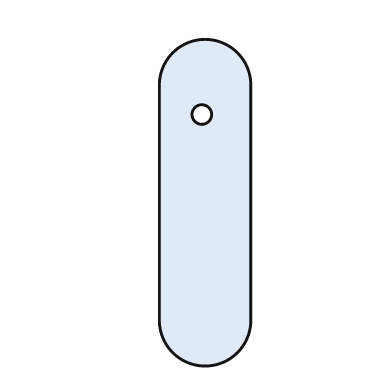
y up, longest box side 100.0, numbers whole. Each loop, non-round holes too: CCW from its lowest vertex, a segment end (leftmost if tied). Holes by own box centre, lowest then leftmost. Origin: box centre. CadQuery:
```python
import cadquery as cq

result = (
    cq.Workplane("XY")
    .moveTo(-14.0, -36.0)
    .threePointArc((0.0, -50.0), (14.0, -36.0))
    .lineTo(14.0, 36.0)
    .threePointArc((0.0, 50.0), (-14.0, 36.0))
    .close()
    .moveTo(-1.0, 27.0)
    .circle(3.0)
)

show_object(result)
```